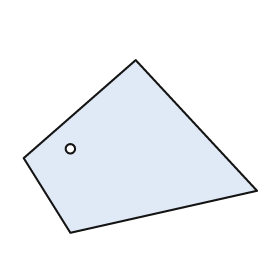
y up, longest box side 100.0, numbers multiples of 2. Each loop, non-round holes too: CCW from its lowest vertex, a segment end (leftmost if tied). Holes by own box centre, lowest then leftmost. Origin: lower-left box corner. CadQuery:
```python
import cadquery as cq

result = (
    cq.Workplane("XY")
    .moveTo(20.0, 0.0)
    .lineTo(100.0, 18.0)
    .lineTo(48.0, 74.0)
    .lineTo(0.0, 32.0)
    .close()
    .moveTo(20.0, 36.0)
    .circle(2.0)
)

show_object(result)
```